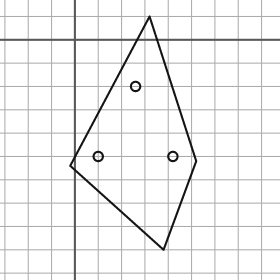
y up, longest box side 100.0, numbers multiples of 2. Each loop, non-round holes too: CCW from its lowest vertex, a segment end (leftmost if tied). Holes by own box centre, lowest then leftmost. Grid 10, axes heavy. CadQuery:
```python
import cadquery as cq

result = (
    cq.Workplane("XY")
    .moveTo(38.0, -90.0)
    .lineTo(52.0, -52.0)
    .lineTo(32.0, 10.0)
    .lineTo(-2.0, -54.0)
    .close()
    .moveTo(10.0, -50.0)
    .circle(2.0)
    .moveTo(42.0, -50.0)
    .circle(2.0)
    .moveTo(26.0, -20.0)
    .circle(2.0)
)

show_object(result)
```